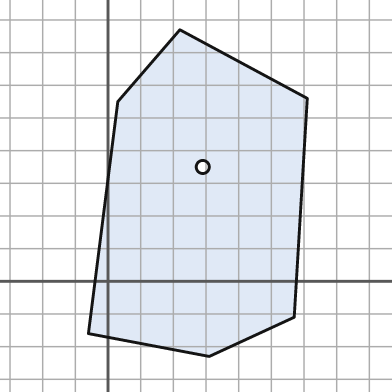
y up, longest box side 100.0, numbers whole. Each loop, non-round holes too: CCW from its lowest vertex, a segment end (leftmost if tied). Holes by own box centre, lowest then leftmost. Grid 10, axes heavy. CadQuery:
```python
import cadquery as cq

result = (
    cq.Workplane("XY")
    .moveTo(31.0, -23.0)
    .lineTo(57.0, -11.0)
    .lineTo(61.0, 56.0)
    .lineTo(22.0, 77.0)
    .lineTo(3.0, 55.0)
    .lineTo(-6.0, -16.0)
    .close()
    .moveTo(29.0, 35.0)
    .circle(2.0)
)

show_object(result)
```